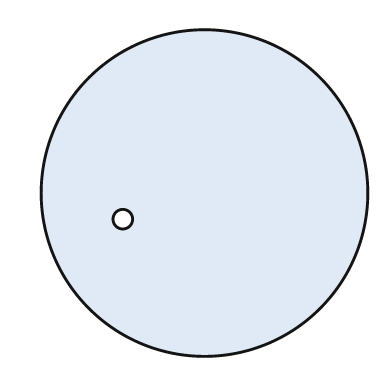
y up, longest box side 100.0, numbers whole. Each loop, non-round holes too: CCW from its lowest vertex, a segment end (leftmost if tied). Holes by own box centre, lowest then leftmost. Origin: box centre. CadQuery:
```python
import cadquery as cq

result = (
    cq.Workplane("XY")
    .moveTo(0.0, 0.0)
    .circle(50.0)
    .moveTo(-25.0, -8.0)
    .circle(3.0)
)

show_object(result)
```